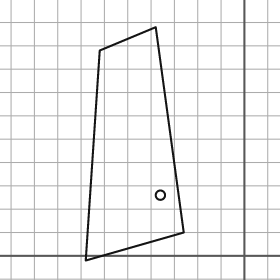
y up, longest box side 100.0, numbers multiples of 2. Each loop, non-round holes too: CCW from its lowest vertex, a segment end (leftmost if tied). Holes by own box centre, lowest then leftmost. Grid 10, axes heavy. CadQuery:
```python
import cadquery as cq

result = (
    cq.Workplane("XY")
    .moveTo(-68.0, -2.0)
    .lineTo(-26.0, 10.0)
    .lineTo(-38.0, 98.0)
    .lineTo(-62.0, 88.0)
    .close()
    .moveTo(-36.0, 26.0)
    .circle(2.0)
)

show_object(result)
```